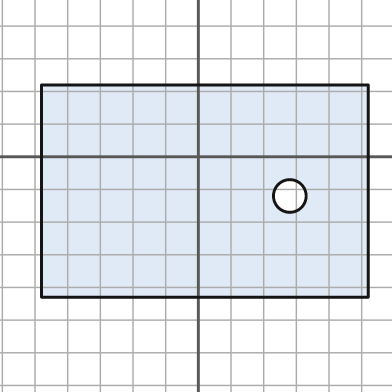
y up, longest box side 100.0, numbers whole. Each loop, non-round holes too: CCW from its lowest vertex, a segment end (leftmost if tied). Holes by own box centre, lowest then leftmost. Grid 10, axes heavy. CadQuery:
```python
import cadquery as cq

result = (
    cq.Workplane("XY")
    .moveTo(-48.0, -43.0)
    .lineTo(52.0, -43.0)
    .lineTo(52.0, 22.0)
    .lineTo(-48.0, 22.0)
    .close()
    .moveTo(28.0, -12.0)
    .circle(5.0)
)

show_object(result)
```